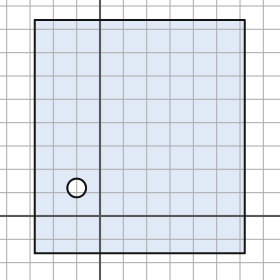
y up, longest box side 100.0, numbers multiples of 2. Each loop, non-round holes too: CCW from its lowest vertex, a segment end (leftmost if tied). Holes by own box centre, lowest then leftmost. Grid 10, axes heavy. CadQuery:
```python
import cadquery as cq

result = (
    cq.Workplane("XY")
    .moveTo(-28.0, -16.0)
    .lineTo(62.0, -16.0)
    .lineTo(62.0, 84.0)
    .lineTo(-28.0, 84.0)
    .close()
    .moveTo(-10.0, 12.0)
    .circle(4.0)
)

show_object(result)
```